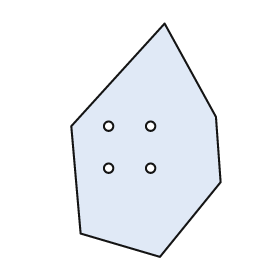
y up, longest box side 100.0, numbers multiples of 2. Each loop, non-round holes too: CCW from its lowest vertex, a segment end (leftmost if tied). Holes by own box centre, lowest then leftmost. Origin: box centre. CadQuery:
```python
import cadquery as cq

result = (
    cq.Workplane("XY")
    .moveTo(6.0, -50.0)
    .lineTo(32.0, -18.0)
    .lineTo(30.0, 10.0)
    .lineTo(8.0, 50.0)
    .lineTo(-32.0, 6.0)
    .lineTo(-28.0, -40.0)
    .close()
    .moveTo(-16.0, -12.0)
    .circle(2.0)
    .moveTo(2.0, -12.0)
    .circle(2.0)
    .moveTo(-16.0, 6.0)
    .circle(2.0)
    .moveTo(2.0, 6.0)
    .circle(2.0)
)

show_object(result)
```